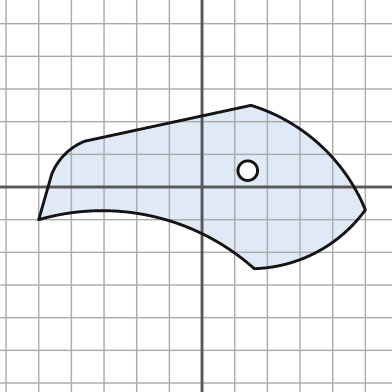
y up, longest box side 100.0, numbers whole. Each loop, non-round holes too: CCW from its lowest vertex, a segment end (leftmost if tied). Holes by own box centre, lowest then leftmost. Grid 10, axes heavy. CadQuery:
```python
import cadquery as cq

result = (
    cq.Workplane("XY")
    .moveTo(16.0, -25.0)
    .threePointArc((35.0, -20.0), (50.0, -7.0))
    .threePointArc((36.0, 13.0), (15.0, 25.0))
    .lineTo(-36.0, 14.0)
    .threePointArc((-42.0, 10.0), (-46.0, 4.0))
    .lineTo(-50.0, -10.0)
    .threePointArc((-15.0, -9.0), (16.0, -25.0))
    .close()
    .moveTo(14.0, 5.0)
    .circle(3.0)
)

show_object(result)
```